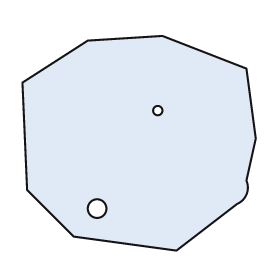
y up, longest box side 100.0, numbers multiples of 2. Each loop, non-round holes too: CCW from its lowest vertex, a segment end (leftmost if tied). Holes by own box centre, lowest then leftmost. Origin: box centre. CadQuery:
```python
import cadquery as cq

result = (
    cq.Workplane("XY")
    .moveTo(16.0, -46.0)
    .lineTo(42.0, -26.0)
    .threePointArc((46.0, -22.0), (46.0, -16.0))
    .lineTo(50.0, 2.0)
    .lineTo(46.0, 32.0)
    .lineTo(10.0, 46.0)
    .lineTo(-22.0, 44.0)
    .lineTo(-50.0, 26.0)
    .lineTo(-48.0, -20.0)
    .lineTo(-28.0, -40.0)
    .close()
    .moveTo(-18.0, -28.0)
    .circle(4.0)
    .moveTo(8.0, 14.0)
    .circle(2.0)
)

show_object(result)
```